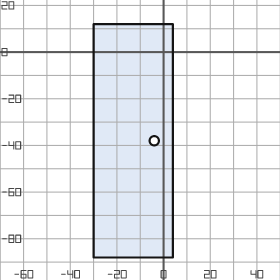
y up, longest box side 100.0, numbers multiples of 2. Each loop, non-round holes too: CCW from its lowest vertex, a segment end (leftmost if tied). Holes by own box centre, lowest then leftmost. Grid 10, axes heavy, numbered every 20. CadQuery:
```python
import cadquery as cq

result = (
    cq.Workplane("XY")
    .moveTo(-30.0, -88.0)
    .lineTo(4.0, -88.0)
    .lineTo(4.0, 12.0)
    .lineTo(-30.0, 12.0)
    .close()
    .moveTo(-4.0, -38.0)
    .circle(2.0)
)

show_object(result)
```